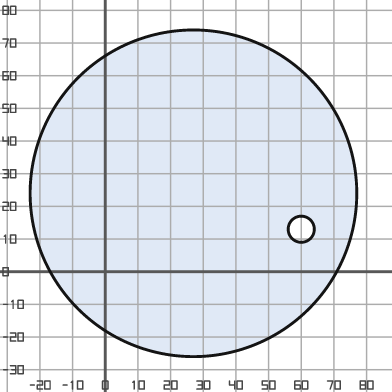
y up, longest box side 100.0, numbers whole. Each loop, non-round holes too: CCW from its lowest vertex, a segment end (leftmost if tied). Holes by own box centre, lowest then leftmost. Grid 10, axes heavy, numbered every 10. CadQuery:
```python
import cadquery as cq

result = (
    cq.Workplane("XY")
    .moveTo(27.0, 24.0)
    .circle(50.0)
    .moveTo(60.0, 13.0)
    .circle(4.0)
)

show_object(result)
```